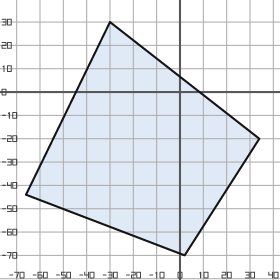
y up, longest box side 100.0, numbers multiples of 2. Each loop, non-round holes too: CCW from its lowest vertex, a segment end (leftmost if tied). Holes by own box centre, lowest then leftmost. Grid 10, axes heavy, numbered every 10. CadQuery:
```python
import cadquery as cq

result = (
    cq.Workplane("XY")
    .moveTo(2.0, -70.0)
    .lineTo(34.0, -20.0)
    .lineTo(-30.0, 30.0)
    .lineTo(-66.0, -44.0)
    .close()
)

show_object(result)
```